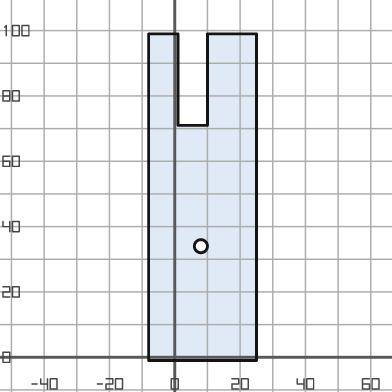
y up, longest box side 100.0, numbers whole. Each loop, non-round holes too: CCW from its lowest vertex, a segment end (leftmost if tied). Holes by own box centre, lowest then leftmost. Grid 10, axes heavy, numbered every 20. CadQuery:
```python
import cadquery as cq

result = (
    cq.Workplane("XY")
    .moveTo(-8.0, -1.0)
    .lineTo(25.0, -1.0)
    .lineTo(25.0, 99.0)
    .lineTo(10.0, 99.0)
    .lineTo(10.0, 71.0)
    .lineTo(1.0, 71.0)
    .lineTo(1.0, 99.0)
    .lineTo(-8.0, 99.0)
    .close()
    .moveTo(8.0, 34.0)
    .circle(2.0)
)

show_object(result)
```